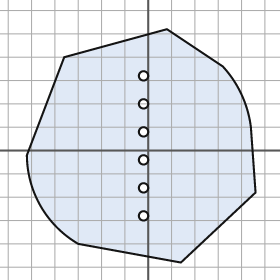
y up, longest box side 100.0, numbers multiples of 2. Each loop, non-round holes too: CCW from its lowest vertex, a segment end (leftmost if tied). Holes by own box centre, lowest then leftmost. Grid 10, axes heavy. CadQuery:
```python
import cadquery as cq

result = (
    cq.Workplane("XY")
    .moveTo(14.0, -48.0)
    .lineTo(46.0, -18.0)
    .lineTo(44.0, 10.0)
    .threePointArc((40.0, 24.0), (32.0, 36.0))
    .lineTo(8.0, 52.0)
    .lineTo(-36.0, 40.0)
    .lineTo(-52.0, -2.0)
    .threePointArc((-46.0, -24.0), (-30.0, -40.0))
    .close()
    .moveTo(-2.0, -28.0)
    .circle(2.0)
    .moveTo(-2.0, -16.0)
    .circle(2.0)
    .moveTo(-2.0, -4.0)
    .circle(2.0)
    .moveTo(-2.0, 8.0)
    .circle(2.0)
    .moveTo(-2.0, 20.0)
    .circle(2.0)
    .moveTo(-2.0, 32.0)
    .circle(2.0)
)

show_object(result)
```